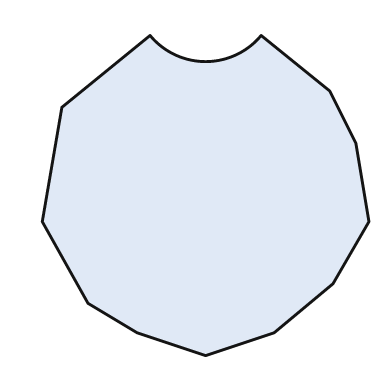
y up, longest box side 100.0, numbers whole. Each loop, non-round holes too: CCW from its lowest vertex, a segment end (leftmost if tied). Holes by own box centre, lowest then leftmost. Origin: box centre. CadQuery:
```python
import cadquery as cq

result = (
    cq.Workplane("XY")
    .moveTo(0.0, -49.0)
    .lineTo(21.0, -42.0)
    .lineTo(39.0, -27.0)
    .lineTo(50.0, -8.0)
    .lineTo(46.0, 16.0)
    .lineTo(38.0, 32.0)
    .lineTo(17.0, 49.0)
    .threePointArc((0.0, 41.0), (-17.0, 49.0))
    .lineTo(-44.0, 27.0)
    .lineTo(-50.0, -8.0)
    .lineTo(-36.0, -33.0)
    .lineTo(-21.0, -42.0)
    .close()
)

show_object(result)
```